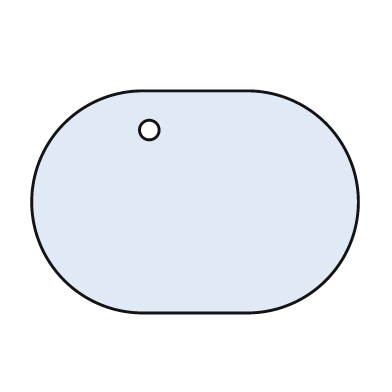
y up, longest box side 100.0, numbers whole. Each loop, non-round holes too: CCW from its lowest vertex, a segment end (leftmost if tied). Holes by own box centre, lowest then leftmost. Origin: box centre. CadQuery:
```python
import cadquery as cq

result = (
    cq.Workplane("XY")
    .moveTo(-16.0, -34.0)
    .lineTo(16.0, -34.0)
    .threePointArc((50.0, 0.0), (16.0, 34.0))
    .lineTo(-16.0, 34.0)
    .threePointArc((-50.0, 0.0), (-16.0, -34.0))
    .close()
    .moveTo(-14.0, 22.0)
    .circle(3.0)
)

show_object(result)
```